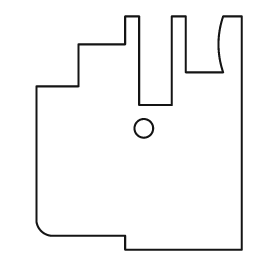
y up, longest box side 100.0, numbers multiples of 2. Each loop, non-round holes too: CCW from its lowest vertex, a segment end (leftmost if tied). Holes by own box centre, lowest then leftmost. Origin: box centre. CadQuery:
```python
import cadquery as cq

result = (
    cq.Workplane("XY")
    .moveTo(-6.0, -50.0)
    .lineTo(44.0, -50.0)
    .lineTo(44.0, 50.0)
    .lineTo(36.0, 50.0)
    .threePointArc((34.0, 38.0), (36.0, 26.0))
    .lineTo(20.0, 26.0)
    .lineTo(20.0, 50.0)
    .lineTo(14.0, 50.0)
    .lineTo(14.0, 12.0)
    .lineTo(0.0, 12.0)
    .lineTo(0.0, 50.0)
    .lineTo(-6.0, 50.0)
    .lineTo(-6.0, 38.0)
    .lineTo(-26.0, 38.0)
    .lineTo(-26.0, 20.0)
    .lineTo(-44.0, 20.0)
    .lineTo(-44.0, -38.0)
    .threePointArc((-42.0, -42.0), (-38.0, -44.0))
    .lineTo(-6.0, -44.0)
    .close()
    .moveTo(2.0, 2.0)
    .circle(4.0)
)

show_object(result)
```